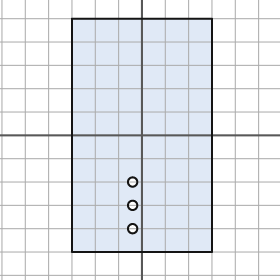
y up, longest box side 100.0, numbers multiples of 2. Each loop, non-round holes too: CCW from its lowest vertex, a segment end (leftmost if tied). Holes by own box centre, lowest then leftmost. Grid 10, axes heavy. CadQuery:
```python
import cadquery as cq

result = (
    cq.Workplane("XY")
    .moveTo(-30.0, -50.0)
    .lineTo(30.0, -50.0)
    .lineTo(30.0, 50.0)
    .lineTo(-30.0, 50.0)
    .close()
    .moveTo(-4.0, -40.0)
    .circle(2.0)
    .moveTo(-4.0, -30.0)
    .circle(2.0)
    .moveTo(-4.0, -20.0)
    .circle(2.0)
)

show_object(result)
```